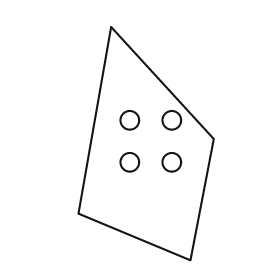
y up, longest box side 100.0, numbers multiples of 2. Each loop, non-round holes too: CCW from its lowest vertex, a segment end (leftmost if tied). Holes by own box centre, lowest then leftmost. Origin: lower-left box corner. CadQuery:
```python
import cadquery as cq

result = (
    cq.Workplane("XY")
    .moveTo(48.0, 0.0)
    .lineTo(58.0, 52.0)
    .lineTo(14.0, 100.0)
    .lineTo(0.0, 20.0)
    .close()
    .moveTo(22.0, 42.0)
    .circle(4.0)
    .moveTo(40.0, 42.0)
    .circle(4.0)
    .moveTo(22.0, 60.0)
    .circle(4.0)
    .moveTo(40.0, 60.0)
    .circle(4.0)
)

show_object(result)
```